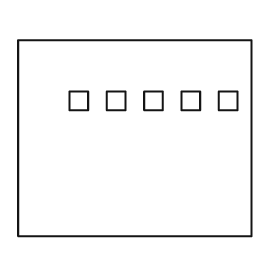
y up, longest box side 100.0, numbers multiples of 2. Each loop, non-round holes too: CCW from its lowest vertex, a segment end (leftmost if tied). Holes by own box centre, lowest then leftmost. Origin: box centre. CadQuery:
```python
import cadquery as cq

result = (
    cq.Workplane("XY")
    .moveTo(-50.0, -42.0)
    .lineTo(50.0, -42.0)
    .lineTo(50.0, 42.0)
    .lineTo(-50.0, 42.0)
    .close()
    .moveTo(-28.0, 12.0)
    .lineTo(-20.0, 12.0)
    .lineTo(-20.0, 20.0)
    .lineTo(-28.0, 20.0)
    .close()
    .moveTo(-12.0, 12.0)
    .lineTo(-4.0, 12.0)
    .lineTo(-4.0, 20.0)
    .lineTo(-12.0, 20.0)
    .close()
    .moveTo(4.0, 12.0)
    .lineTo(12.0, 12.0)
    .lineTo(12.0, 20.0)
    .lineTo(4.0, 20.0)
    .close()
    .moveTo(20.0, 12.0)
    .lineTo(28.0, 12.0)
    .lineTo(28.0, 20.0)
    .lineTo(20.0, 20.0)
    .close()
    .moveTo(36.0, 12.0)
    .lineTo(44.0, 12.0)
    .lineTo(44.0, 20.0)
    .lineTo(36.0, 20.0)
    .close()
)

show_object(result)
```